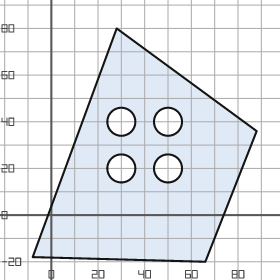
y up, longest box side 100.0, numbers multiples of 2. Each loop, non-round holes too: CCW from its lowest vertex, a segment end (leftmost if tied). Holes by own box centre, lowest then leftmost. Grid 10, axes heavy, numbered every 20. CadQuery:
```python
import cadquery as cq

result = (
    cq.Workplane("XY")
    .moveTo(66.0, -20.0)
    .lineTo(88.0, 36.0)
    .lineTo(28.0, 80.0)
    .lineTo(-8.0, -18.0)
    .close()
    .moveTo(30.0, 20.0)
    .circle(6.0)
    .moveTo(50.0, 20.0)
    .circle(6.0)
    .moveTo(30.0, 40.0)
    .circle(6.0)
    .moveTo(50.0, 40.0)
    .circle(6.0)
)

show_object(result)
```